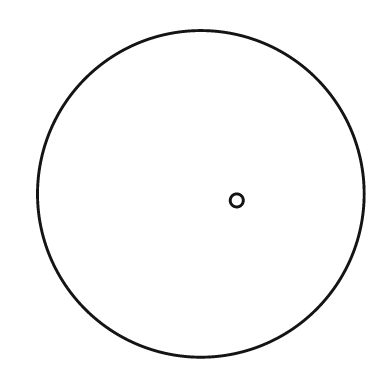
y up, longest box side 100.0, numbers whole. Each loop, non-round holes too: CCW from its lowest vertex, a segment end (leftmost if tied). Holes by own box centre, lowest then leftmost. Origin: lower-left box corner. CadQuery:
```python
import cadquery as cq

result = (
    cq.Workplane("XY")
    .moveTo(50.0, 50.0)
    .circle(50.0)
    .moveTo(61.0, 48.0)
    .circle(2.0)
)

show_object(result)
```